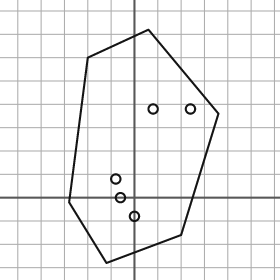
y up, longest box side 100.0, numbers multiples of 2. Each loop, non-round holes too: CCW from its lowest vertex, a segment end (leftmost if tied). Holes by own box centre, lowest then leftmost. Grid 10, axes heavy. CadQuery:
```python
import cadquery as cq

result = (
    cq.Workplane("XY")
    .moveTo(-12.0, -28.0)
    .lineTo(20.0, -16.0)
    .lineTo(36.0, 36.0)
    .lineTo(6.0, 72.0)
    .lineTo(-20.0, 60.0)
    .lineTo(-28.0, -2.0)
    .close()
    .moveTo(0.0, -8.0)
    .circle(2.0)
    .moveTo(-6.0, 0.0)
    .circle(2.0)
    .moveTo(-8.0, 8.0)
    .circle(2.0)
    .moveTo(8.0, 38.0)
    .circle(2.0)
    .moveTo(24.0, 38.0)
    .circle(2.0)
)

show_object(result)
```